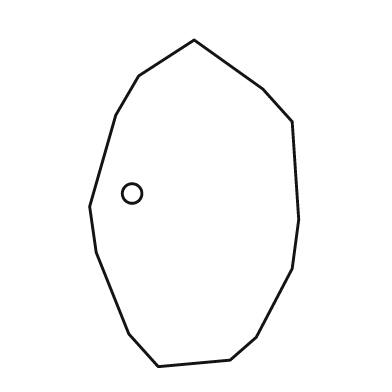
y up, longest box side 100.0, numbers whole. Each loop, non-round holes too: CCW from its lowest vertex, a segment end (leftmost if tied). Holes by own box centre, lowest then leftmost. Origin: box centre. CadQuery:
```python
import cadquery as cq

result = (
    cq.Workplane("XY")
    .moveTo(-11.0, -50.0)
    .lineTo(11.0, -48.0)
    .lineTo(19.0, -41.0)
    .lineTo(30.0, -20.0)
    .lineTo(32.0, -5.0)
    .lineTo(30.0, 25.0)
    .lineTo(21.0, 35.0)
    .lineTo(0.0, 50.0)
    .lineTo(-17.0, 39.0)
    .lineTo(-24.0, 27.0)
    .lineTo(-32.0, -1.0)
    .lineTo(-30.0, -15.0)
    .lineTo(-20.0, -40.0)
    .close()
    .moveTo(-19.0, 3.0)
    .circle(3.0)
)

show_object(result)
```